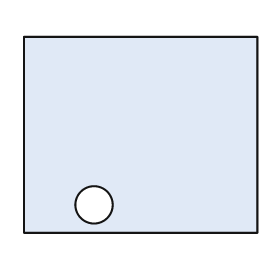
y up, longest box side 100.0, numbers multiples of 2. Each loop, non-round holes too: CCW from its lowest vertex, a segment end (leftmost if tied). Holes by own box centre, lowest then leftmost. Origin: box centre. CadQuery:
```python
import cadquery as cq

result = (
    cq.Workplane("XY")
    .moveTo(-50.0, -42.0)
    .lineTo(50.0, -42.0)
    .lineTo(50.0, 42.0)
    .lineTo(-50.0, 42.0)
    .close()
    .moveTo(-20.0, -30.0)
    .circle(8.0)
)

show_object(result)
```